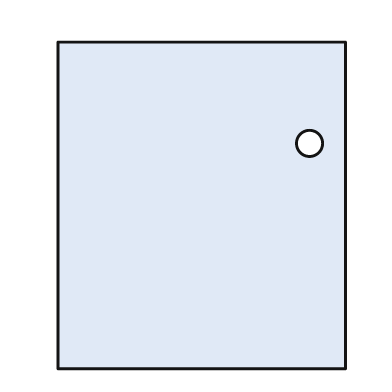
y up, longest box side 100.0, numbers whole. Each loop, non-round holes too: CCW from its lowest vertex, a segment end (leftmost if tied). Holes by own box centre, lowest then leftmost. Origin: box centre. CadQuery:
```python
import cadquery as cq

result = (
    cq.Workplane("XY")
    .moveTo(-44.0, -50.0)
    .lineTo(44.0, -50.0)
    .lineTo(44.0, 50.0)
    .lineTo(-44.0, 50.0)
    .close()
    .moveTo(33.0, 19.0)
    .circle(4.0)
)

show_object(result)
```